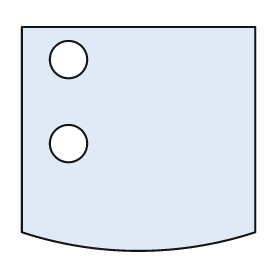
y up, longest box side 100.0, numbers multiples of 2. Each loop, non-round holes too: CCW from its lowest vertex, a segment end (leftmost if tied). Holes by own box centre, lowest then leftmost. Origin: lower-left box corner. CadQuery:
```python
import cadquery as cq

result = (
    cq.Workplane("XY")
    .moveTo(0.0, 8.0)
    .threePointArc((50.0, 0.0), (100.0, 8.0))
    .lineTo(100.0, 96.0)
    .lineTo(0.0, 96.0)
    .close()
    .moveTo(20.0, 46.0)
    .circle(8.0)
    .moveTo(20.0, 82.0)
    .circle(8.0)
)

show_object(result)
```